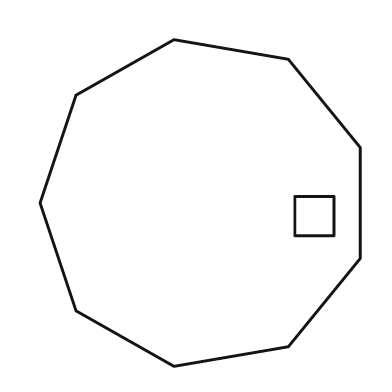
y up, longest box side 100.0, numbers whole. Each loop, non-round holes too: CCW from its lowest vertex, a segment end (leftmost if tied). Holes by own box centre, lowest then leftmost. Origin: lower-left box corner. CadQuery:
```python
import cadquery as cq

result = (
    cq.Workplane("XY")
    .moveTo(41.0, 0.0)
    .lineTo(76.0, 6.0)
    .lineTo(98.0, 33.0)
    .lineTo(98.0, 67.0)
    .lineTo(76.0, 94.0)
    .lineTo(41.0, 100.0)
    .lineTo(11.0, 83.0)
    .lineTo(0.0, 50.0)
    .lineTo(11.0, 17.0)
    .close()
    .moveTo(78.0, 40.0)
    .lineTo(90.0, 40.0)
    .lineTo(90.0, 52.0)
    .lineTo(78.0, 52.0)
    .close()
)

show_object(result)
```